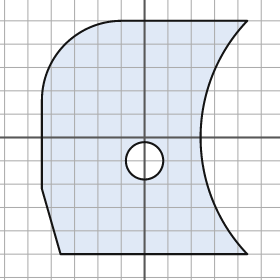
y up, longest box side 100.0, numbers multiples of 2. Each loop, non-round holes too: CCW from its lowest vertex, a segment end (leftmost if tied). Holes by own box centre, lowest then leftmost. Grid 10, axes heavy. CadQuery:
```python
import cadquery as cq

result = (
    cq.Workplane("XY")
    .moveTo(-36.0, -50.0)
    .lineTo(44.0, -50.0)
    .threePointArc((24.0, 0.0), (44.0, 50.0))
    .lineTo(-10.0, 50.0)
    .threePointArc((-34.0, 40.0), (-44.0, 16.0))
    .lineTo(-44.0, -22.0)
    .close()
    .moveTo(0.0, -10.0)
    .circle(8.0)
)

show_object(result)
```